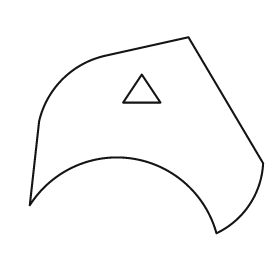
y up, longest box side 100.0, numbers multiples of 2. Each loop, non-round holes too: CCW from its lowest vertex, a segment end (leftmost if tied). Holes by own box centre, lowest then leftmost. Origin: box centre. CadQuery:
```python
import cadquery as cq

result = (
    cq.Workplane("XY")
    .moveTo(30.0, -42.0)
    .threePointArc((44.0, -30.0), (50.0, -12.0))
    .lineTo(18.0, 42.0)
    .lineTo(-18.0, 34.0)
    .threePointArc((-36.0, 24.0), (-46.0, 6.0))
    .lineTo(-50.0, -30.0)
    .threePointArc((-6.0, -10.0), (30.0, -42.0))
    .close()
    .moveTo(-10.0, 14.0)
    .lineTo(6.0, 14.0)
    .lineTo(-2.0, 26.0)
    .close()
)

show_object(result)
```